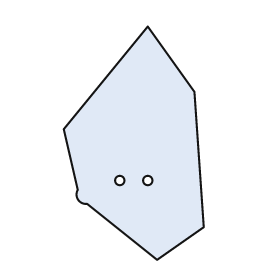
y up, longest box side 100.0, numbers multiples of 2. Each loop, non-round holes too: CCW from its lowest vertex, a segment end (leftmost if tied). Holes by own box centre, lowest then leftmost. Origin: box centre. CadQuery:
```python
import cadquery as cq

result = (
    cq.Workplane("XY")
    .moveTo(10.0, -50.0)
    .lineTo(30.0, -36.0)
    .lineTo(26.0, 22.0)
    .lineTo(6.0, 50.0)
    .lineTo(-30.0, 6.0)
    .lineTo(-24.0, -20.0)
    .threePointArc((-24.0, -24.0), (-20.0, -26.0))
    .close()
    .moveTo(-6.0, -16.0)
    .circle(2.0)
    .moveTo(6.0, -16.0)
    .circle(2.0)
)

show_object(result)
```